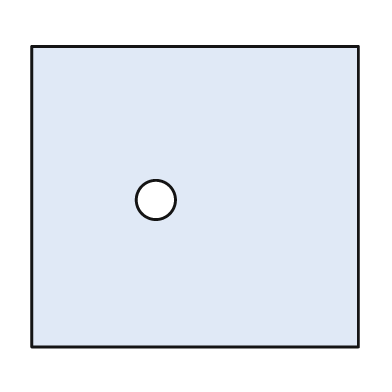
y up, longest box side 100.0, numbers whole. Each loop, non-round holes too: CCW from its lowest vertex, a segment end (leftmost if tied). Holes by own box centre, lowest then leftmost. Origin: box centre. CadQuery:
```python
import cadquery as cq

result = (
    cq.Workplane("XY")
    .moveTo(-50.0, -46.0)
    .lineTo(50.0, -46.0)
    .lineTo(50.0, 46.0)
    .lineTo(-50.0, 46.0)
    .close()
    .moveTo(-12.0, -1.0)
    .circle(6.0)
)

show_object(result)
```